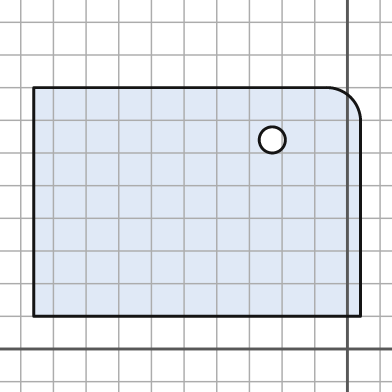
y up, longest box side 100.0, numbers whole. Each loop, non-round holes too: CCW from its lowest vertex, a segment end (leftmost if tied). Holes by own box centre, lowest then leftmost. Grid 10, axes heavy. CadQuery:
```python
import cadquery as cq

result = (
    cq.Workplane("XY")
    .moveTo(-96.0, 10.0)
    .lineTo(4.0, 10.0)
    .lineTo(4.0, 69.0)
    .threePointArc((1.0, 77.0), (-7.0, 80.0))
    .lineTo(-96.0, 80.0)
    .close()
    .moveTo(-23.0, 64.0)
    .circle(4.0)
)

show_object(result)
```